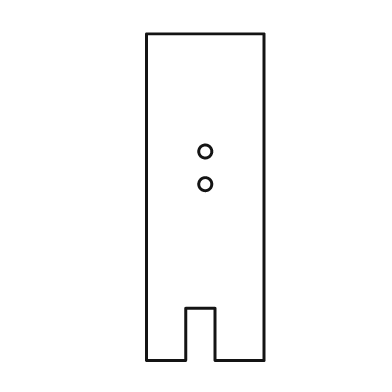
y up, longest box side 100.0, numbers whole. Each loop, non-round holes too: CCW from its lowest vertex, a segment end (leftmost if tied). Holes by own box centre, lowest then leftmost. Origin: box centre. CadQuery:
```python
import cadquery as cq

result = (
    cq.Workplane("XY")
    .moveTo(-18.0, -50.0)
    .lineTo(-6.0, -50.0)
    .lineTo(-6.0, -34.0)
    .lineTo(3.0, -34.0)
    .lineTo(3.0, -50.0)
    .lineTo(18.0, -50.0)
    .lineTo(18.0, 50.0)
    .lineTo(-18.0, 50.0)
    .close()
    .moveTo(0.0, 4.0)
    .circle(2.0)
    .moveTo(0.0, 14.0)
    .circle(2.0)
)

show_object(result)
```